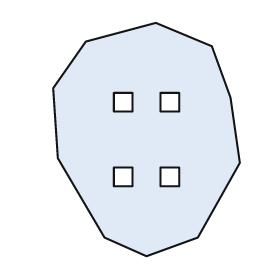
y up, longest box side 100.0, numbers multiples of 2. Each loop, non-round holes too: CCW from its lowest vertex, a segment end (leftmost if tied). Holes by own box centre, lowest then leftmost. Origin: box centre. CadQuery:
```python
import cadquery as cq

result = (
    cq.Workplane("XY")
    .moveTo(0.0, -50.0)
    .lineTo(22.0, -42.0)
    .lineTo(40.0, -10.0)
    .lineTo(36.0, 18.0)
    .lineTo(28.0, 40.0)
    .lineTo(4.0, 50.0)
    .lineTo(-26.0, 42.0)
    .lineTo(-40.0, 22.0)
    .lineTo(-38.0, -8.0)
    .lineTo(-18.0, -42.0)
    .close()
    .moveTo(-14.0, -20.0)
    .lineTo(-6.0, -20.0)
    .lineTo(-6.0, -12.0)
    .lineTo(-14.0, -12.0)
    .close()
    .moveTo(6.0, -20.0)
    .lineTo(14.0, -20.0)
    .lineTo(14.0, -12.0)
    .lineTo(6.0, -12.0)
    .close()
    .moveTo(-14.0, 12.0)
    .lineTo(-6.0, 12.0)
    .lineTo(-6.0, 20.0)
    .lineTo(-14.0, 20.0)
    .close()
    .moveTo(6.0, 12.0)
    .lineTo(14.0, 12.0)
    .lineTo(14.0, 20.0)
    .lineTo(6.0, 20.0)
    .close()
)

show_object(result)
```